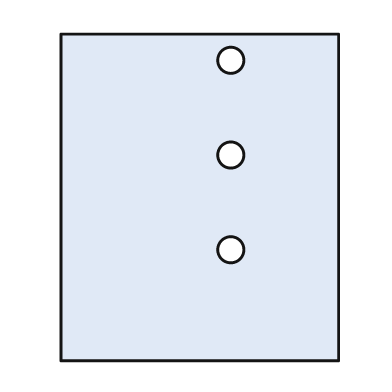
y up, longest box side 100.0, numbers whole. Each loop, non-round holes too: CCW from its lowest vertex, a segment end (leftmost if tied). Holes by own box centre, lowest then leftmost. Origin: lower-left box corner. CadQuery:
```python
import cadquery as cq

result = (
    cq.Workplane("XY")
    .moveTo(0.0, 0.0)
    .lineTo(85.0, 0.0)
    .lineTo(85.0, 100.0)
    .lineTo(0.0, 100.0)
    .close()
    .moveTo(52.0, 34.0)
    .circle(4.0)
    .moveTo(52.0, 63.0)
    .circle(4.0)
    .moveTo(52.0, 92.0)
    .circle(4.0)
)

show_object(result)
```